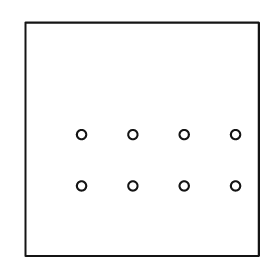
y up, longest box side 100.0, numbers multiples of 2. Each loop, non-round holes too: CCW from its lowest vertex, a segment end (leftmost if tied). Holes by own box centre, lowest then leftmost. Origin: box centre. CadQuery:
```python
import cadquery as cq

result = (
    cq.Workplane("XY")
    .moveTo(-50.0, -50.0)
    .lineTo(50.0, -50.0)
    .lineTo(50.0, 50.0)
    .lineTo(-50.0, 50.0)
    .close()
    .moveTo(-26.0, -20.0)
    .circle(2.0)
    .moveTo(-4.0, -20.0)
    .circle(2.0)
    .moveTo(18.0, -20.0)
    .circle(2.0)
    .moveTo(40.0, -20.0)
    .circle(2.0)
    .moveTo(-26.0, 2.0)
    .circle(2.0)
    .moveTo(-4.0, 2.0)
    .circle(2.0)
    .moveTo(18.0, 2.0)
    .circle(2.0)
    .moveTo(40.0, 2.0)
    .circle(2.0)
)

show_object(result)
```